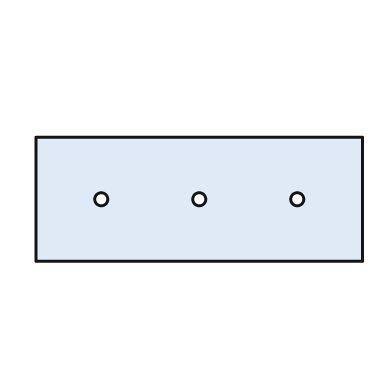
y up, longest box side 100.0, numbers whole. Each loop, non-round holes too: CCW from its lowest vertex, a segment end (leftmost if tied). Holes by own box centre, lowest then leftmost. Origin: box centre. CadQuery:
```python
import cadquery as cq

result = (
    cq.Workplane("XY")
    .moveTo(-50.0, -19.0)
    .lineTo(50.0, -19.0)
    .lineTo(50.0, 19.0)
    .lineTo(-50.0, 19.0)
    .close()
    .moveTo(-30.0, 0.0)
    .circle(2.0)
    .moveTo(0.0, 0.0)
    .circle(2.0)
    .moveTo(30.0, 0.0)
    .circle(2.0)
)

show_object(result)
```